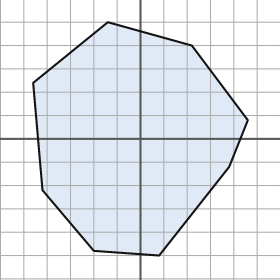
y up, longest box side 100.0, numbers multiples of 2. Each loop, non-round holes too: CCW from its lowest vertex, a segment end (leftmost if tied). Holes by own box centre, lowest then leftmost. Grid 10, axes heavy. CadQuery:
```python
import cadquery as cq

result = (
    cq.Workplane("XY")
    .moveTo(8.0, -50.0)
    .lineTo(38.0, -12.0)
    .lineTo(46.0, 8.0)
    .lineTo(22.0, 40.0)
    .lineTo(-14.0, 50.0)
    .lineTo(-46.0, 24.0)
    .lineTo(-42.0, -22.0)
    .lineTo(-20.0, -48.0)
    .close()
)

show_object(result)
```